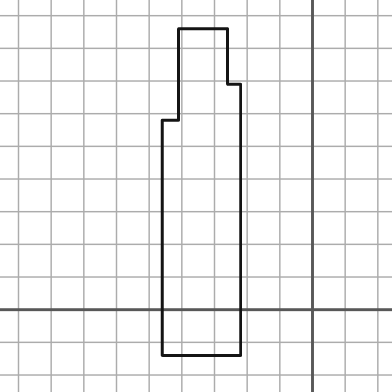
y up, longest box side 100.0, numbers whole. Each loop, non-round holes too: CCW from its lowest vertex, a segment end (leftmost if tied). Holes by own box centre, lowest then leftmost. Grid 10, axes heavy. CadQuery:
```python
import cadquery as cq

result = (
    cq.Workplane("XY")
    .moveTo(-46.0, -14.0)
    .lineTo(-22.0, -14.0)
    .lineTo(-22.0, 69.0)
    .lineTo(-26.0, 69.0)
    .lineTo(-26.0, 86.0)
    .lineTo(-41.0, 86.0)
    .lineTo(-41.0, 58.0)
    .lineTo(-46.0, 58.0)
    .close()
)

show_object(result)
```